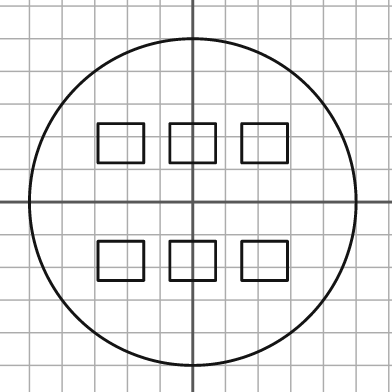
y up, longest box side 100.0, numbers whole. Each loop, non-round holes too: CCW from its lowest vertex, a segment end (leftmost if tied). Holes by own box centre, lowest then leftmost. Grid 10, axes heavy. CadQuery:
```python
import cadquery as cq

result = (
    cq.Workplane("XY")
    .moveTo(0.0, 0.0)
    .circle(50.0)
    .moveTo(-29.0, -24.0)
    .lineTo(-15.0, -24.0)
    .lineTo(-15.0, -12.0)
    .lineTo(-29.0, -12.0)
    .close()
    .moveTo(-7.0, -24.0)
    .lineTo(7.0, -24.0)
    .lineTo(7.0, -12.0)
    .lineTo(-7.0, -12.0)
    .close()
    .moveTo(15.0, -24.0)
    .lineTo(29.0, -24.0)
    .lineTo(29.0, -12.0)
    .lineTo(15.0, -12.0)
    .close()
    .moveTo(-29.0, 12.0)
    .lineTo(-15.0, 12.0)
    .lineTo(-15.0, 24.0)
    .lineTo(-29.0, 24.0)
    .close()
    .moveTo(-7.0, 12.0)
    .lineTo(7.0, 12.0)
    .lineTo(7.0, 24.0)
    .lineTo(-7.0, 24.0)
    .close()
    .moveTo(15.0, 12.0)
    .lineTo(29.0, 12.0)
    .lineTo(29.0, 24.0)
    .lineTo(15.0, 24.0)
    .close()
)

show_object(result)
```